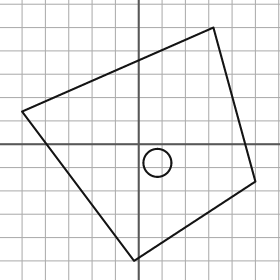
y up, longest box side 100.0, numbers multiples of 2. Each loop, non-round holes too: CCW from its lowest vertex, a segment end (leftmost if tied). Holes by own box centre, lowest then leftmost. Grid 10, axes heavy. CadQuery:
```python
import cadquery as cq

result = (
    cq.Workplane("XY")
    .moveTo(-2.0, -50.0)
    .lineTo(50.0, -16.0)
    .lineTo(32.0, 50.0)
    .lineTo(-50.0, 14.0)
    .close()
    .moveTo(8.0, -8.0)
    .circle(6.0)
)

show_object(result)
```